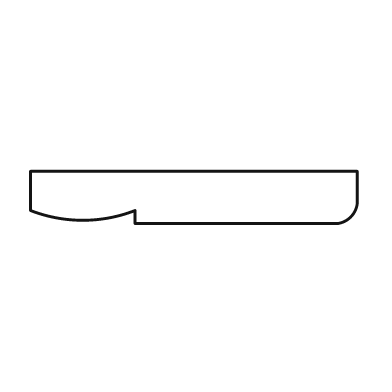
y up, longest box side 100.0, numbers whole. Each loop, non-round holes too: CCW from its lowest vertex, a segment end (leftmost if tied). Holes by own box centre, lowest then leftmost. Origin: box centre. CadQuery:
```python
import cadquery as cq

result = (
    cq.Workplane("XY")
    .moveTo(-18.0, -8.0)
    .lineTo(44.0, -8.0)
    .threePointArc((48.0, -6.0), (50.0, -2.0))
    .lineTo(50.0, 8.0)
    .lineTo(-50.0, 8.0)
    .lineTo(-50.0, -4.0)
    .threePointArc((-34.0, -7.0), (-18.0, -4.0))
    .close()
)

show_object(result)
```